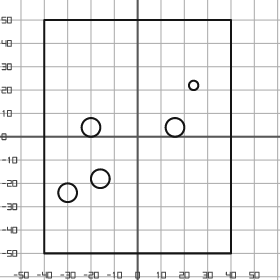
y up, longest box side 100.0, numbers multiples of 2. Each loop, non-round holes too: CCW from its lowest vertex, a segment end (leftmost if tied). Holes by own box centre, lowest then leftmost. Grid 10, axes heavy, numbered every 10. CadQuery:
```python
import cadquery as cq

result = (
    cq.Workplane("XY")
    .moveTo(-40.0, -50.0)
    .lineTo(40.0, -50.0)
    .lineTo(40.0, 50.0)
    .lineTo(-40.0, 50.0)
    .close()
    .moveTo(-30.0, -24.0)
    .circle(4.0)
    .moveTo(-16.0, -18.0)
    .circle(4.0)
    .moveTo(-20.0, 4.0)
    .circle(4.0)
    .moveTo(16.0, 4.0)
    .circle(4.0)
    .moveTo(24.0, 22.0)
    .circle(2.0)
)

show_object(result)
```